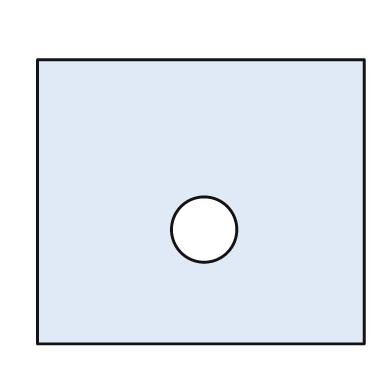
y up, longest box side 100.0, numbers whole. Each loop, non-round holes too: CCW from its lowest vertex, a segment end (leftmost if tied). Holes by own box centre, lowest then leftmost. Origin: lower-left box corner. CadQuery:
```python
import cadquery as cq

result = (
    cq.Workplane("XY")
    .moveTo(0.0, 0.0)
    .lineTo(100.0, 0.0)
    .lineTo(100.0, 87.0)
    .lineTo(0.0, 87.0)
    .close()
    .moveTo(51.0, 35.0)
    .circle(10.0)
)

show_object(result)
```